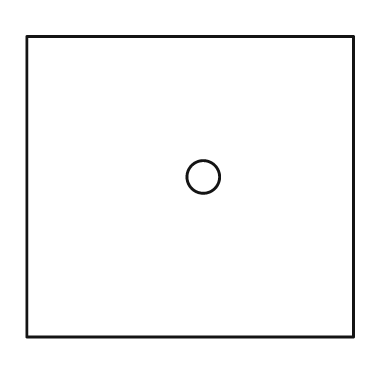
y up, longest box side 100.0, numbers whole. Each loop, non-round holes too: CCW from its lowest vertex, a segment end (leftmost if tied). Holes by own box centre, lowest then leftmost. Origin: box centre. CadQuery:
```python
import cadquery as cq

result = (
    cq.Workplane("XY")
    .moveTo(-50.0, -46.0)
    .lineTo(50.0, -46.0)
    .lineTo(50.0, 46.0)
    .lineTo(-50.0, 46.0)
    .close()
    .moveTo(4.0, 3.0)
    .circle(5.0)
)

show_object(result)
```